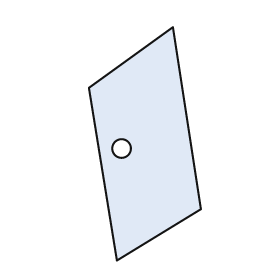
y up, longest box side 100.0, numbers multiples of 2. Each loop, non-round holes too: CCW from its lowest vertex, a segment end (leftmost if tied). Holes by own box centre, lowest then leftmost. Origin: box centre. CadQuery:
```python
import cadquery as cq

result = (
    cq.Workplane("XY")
    .moveTo(-12.0, -50.0)
    .lineTo(24.0, -28.0)
    .lineTo(12.0, 50.0)
    .lineTo(-24.0, 24.0)
    .close()
    .moveTo(-10.0, -2.0)
    .circle(4.0)
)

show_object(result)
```